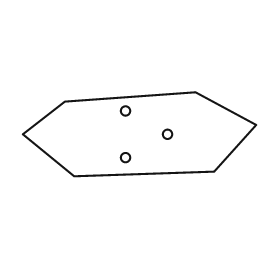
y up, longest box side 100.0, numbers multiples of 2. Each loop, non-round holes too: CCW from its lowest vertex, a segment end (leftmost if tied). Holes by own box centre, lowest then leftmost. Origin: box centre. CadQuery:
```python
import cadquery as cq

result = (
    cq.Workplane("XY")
    .moveTo(-28.0, -18.0)
    .lineTo(32.0, -16.0)
    .lineTo(50.0, 4.0)
    .lineTo(24.0, 18.0)
    .lineTo(-32.0, 14.0)
    .lineTo(-50.0, 0.0)
    .close()
    .moveTo(-6.0, -10.0)
    .circle(2.0)
    .moveTo(12.0, 0.0)
    .circle(2.0)
    .moveTo(-6.0, 10.0)
    .circle(2.0)
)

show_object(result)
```